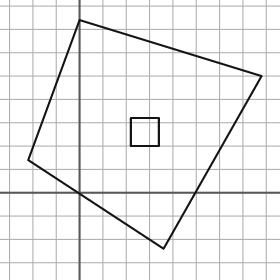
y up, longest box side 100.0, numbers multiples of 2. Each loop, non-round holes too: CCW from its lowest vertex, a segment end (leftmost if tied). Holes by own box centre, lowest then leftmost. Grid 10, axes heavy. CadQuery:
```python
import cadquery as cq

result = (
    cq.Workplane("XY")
    .moveTo(36.0, -24.0)
    .lineTo(78.0, 50.0)
    .lineTo(0.0, 74.0)
    .lineTo(-22.0, 14.0)
    .close()
    .moveTo(22.0, 20.0)
    .lineTo(34.0, 20.0)
    .lineTo(34.0, 32.0)
    .lineTo(22.0, 32.0)
    .close()
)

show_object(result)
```